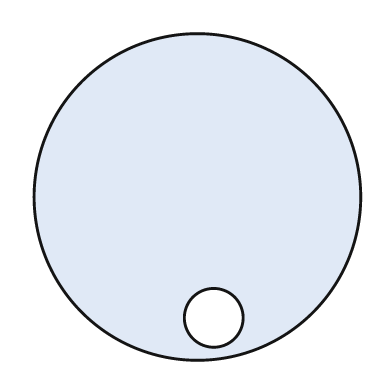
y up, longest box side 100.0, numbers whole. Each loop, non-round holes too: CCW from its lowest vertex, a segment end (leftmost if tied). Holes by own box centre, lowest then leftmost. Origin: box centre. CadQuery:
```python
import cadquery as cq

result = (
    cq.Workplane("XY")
    .moveTo(0.0, 0.0)
    .circle(50.0)
    .moveTo(5.0, -37.0)
    .circle(9.0)
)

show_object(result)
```